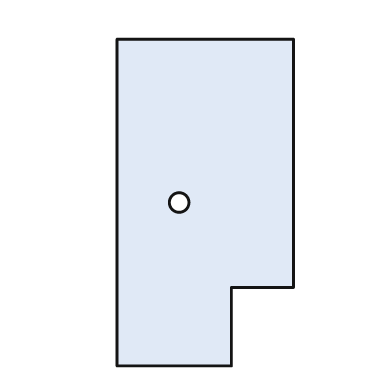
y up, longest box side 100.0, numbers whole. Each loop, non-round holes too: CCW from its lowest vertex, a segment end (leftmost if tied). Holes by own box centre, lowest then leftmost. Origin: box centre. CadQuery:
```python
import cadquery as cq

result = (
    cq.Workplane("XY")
    .moveTo(-27.0, -50.0)
    .lineTo(8.0, -50.0)
    .lineTo(8.0, -26.0)
    .lineTo(27.0, -26.0)
    .lineTo(27.0, 50.0)
    .lineTo(-27.0, 50.0)
    .close()
    .moveTo(-8.0, 0.0)
    .circle(3.0)
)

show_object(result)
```